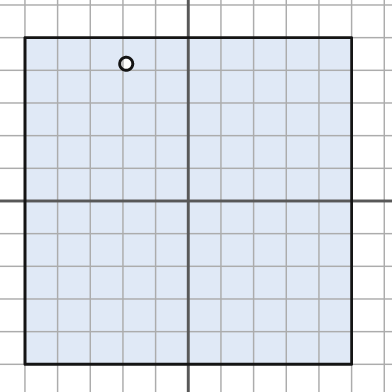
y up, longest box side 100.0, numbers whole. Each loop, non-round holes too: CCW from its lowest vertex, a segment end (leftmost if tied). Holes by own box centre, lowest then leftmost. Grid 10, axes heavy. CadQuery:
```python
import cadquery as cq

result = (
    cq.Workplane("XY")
    .moveTo(-50.0, -50.0)
    .lineTo(50.0, -50.0)
    .lineTo(50.0, 50.0)
    .lineTo(-50.0, 50.0)
    .close()
    .moveTo(-19.0, 42.0)
    .circle(2.0)
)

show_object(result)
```